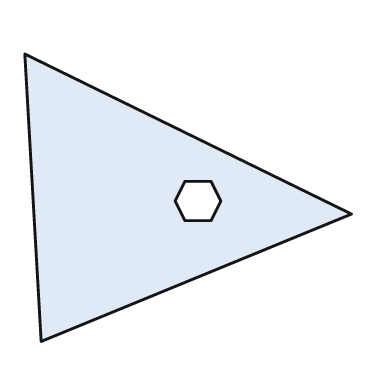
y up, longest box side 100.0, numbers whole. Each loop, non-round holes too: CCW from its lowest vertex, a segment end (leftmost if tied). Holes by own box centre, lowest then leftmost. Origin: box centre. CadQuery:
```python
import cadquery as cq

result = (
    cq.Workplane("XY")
    .moveTo(-45.0, -44.0)
    .lineTo(50.0, -5.0)
    .lineTo(-50.0, 44.0)
    .close()
    .moveTo(-1.0, -7.0)
    .lineTo(7.0, -7.0)
    .lineTo(10.0, -1.0)
    .lineTo(7.0, 5.0)
    .lineTo(-1.0, 5.0)
    .lineTo(-4.0, -1.0)
    .close()
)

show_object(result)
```